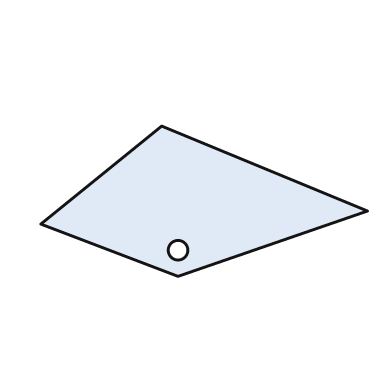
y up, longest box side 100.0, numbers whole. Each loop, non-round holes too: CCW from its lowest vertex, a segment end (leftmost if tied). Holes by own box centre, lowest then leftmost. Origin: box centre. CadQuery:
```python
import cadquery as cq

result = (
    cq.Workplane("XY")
    .moveTo(-8.0, -23.0)
    .lineTo(50.0, -3.0)
    .lineTo(-13.0, 23.0)
    .lineTo(-50.0, -7.0)
    .close()
    .moveTo(-8.0, -15.0)
    .circle(3.0)
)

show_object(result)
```